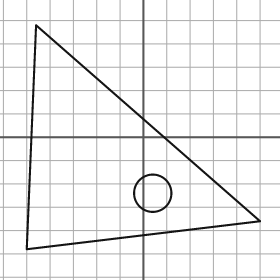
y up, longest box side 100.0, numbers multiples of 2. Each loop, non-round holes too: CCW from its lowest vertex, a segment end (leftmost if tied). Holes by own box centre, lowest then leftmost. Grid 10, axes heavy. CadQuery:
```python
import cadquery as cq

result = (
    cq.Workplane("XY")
    .moveTo(-50.0, -48.0)
    .lineTo(50.0, -36.0)
    .lineTo(-46.0, 48.0)
    .close()
    .moveTo(4.0, -24.0)
    .circle(8.0)
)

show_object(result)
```